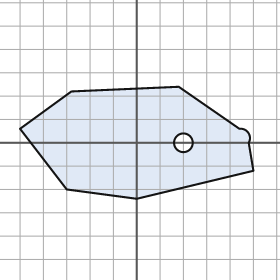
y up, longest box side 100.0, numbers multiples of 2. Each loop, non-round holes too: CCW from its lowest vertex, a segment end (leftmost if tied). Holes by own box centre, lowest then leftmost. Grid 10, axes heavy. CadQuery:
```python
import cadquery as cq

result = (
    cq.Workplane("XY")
    .moveTo(0.0, -24.0)
    .lineTo(50.0, -12.0)
    .lineTo(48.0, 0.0)
    .threePointArc((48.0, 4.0), (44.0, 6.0))
    .lineTo(18.0, 24.0)
    .lineTo(-28.0, 22.0)
    .lineTo(-50.0, 6.0)
    .lineTo(-30.0, -20.0)
    .close()
    .moveTo(20.0, 0.0)
    .circle(4.0)
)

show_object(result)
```